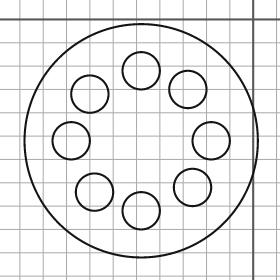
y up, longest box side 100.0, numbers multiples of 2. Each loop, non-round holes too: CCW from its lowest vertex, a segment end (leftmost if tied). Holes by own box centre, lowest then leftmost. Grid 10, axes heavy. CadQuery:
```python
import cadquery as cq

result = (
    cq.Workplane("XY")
    .moveTo(-48.0, -52.0)
    .circle(50.0)
    .moveTo(-48.0, -82.0)
    .circle(8.0)
    .moveTo(-68.0, -74.0)
    .circle(8.0)
    .moveTo(-26.0, -72.0)
    .circle(8.0)
    .moveTo(-78.0, -52.0)
    .circle(8.0)
    .moveTo(-18.0, -52.0)
    .circle(8.0)
    .moveTo(-70.0, -32.0)
    .circle(8.0)
    .moveTo(-28.0, -30.0)
    .circle(8.0)
    .moveTo(-48.0, -22.0)
    .circle(8.0)
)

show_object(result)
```